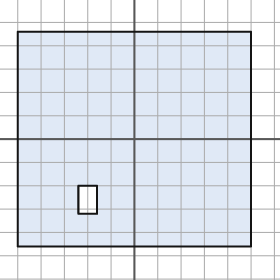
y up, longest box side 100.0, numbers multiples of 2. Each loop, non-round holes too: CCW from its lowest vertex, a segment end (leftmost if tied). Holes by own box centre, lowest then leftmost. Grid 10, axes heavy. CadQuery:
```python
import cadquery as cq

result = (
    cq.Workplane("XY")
    .moveTo(-50.0, -46.0)
    .lineTo(50.0, -46.0)
    .lineTo(50.0, 46.0)
    .lineTo(-50.0, 46.0)
    .close()
    .moveTo(-24.0, -32.0)
    .lineTo(-16.0, -32.0)
    .lineTo(-16.0, -20.0)
    .lineTo(-24.0, -20.0)
    .close()
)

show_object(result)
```